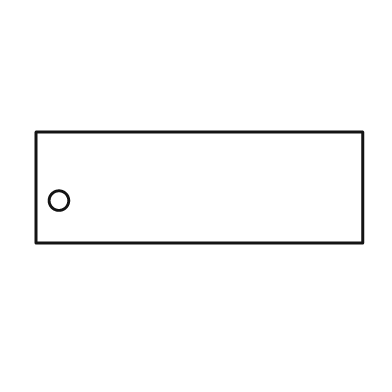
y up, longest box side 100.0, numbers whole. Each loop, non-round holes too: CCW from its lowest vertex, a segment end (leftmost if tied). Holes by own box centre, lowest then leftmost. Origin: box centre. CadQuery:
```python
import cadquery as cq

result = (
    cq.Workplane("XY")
    .moveTo(-50.0, -17.0)
    .lineTo(50.0, -17.0)
    .lineTo(50.0, 17.0)
    .lineTo(-50.0, 17.0)
    .close()
    .moveTo(-43.0, -4.0)
    .circle(3.0)
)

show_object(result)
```